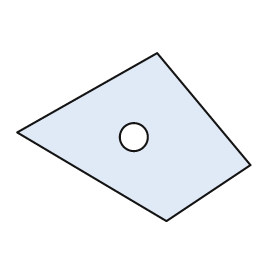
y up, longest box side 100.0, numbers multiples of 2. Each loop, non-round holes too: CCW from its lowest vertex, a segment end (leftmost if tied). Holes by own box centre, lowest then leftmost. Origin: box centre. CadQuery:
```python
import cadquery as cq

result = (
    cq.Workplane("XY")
    .moveTo(14.0, -36.0)
    .lineTo(50.0, -12.0)
    .lineTo(10.0, 36.0)
    .lineTo(-50.0, 2.0)
    .close()
    .moveTo(0.0, 0.0)
    .circle(6.0)
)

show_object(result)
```